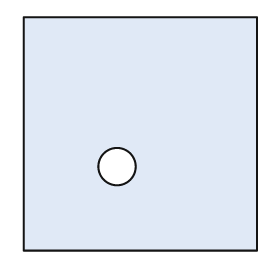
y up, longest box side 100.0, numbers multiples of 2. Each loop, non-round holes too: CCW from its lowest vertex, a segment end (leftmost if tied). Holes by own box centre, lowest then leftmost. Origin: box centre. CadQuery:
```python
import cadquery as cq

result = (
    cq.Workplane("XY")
    .moveTo(-50.0, -50.0)
    .lineTo(50.0, -50.0)
    .lineTo(50.0, 50.0)
    .lineTo(-50.0, 50.0)
    .close()
    .moveTo(-10.0, -14.0)
    .circle(8.0)
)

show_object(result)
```